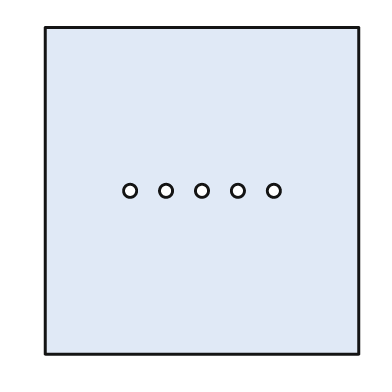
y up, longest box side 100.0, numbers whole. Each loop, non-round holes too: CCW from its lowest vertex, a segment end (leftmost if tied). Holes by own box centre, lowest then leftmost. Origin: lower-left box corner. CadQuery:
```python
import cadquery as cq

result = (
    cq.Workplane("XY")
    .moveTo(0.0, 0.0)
    .lineTo(96.0, 0.0)
    .lineTo(96.0, 100.0)
    .lineTo(0.0, 100.0)
    .close()
    .moveTo(26.0, 50.0)
    .circle(2.0)
    .moveTo(37.0, 50.0)
    .circle(2.0)
    .moveTo(48.0, 50.0)
    .circle(2.0)
    .moveTo(59.0, 50.0)
    .circle(2.0)
    .moveTo(70.0, 50.0)
    .circle(2.0)
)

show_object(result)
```